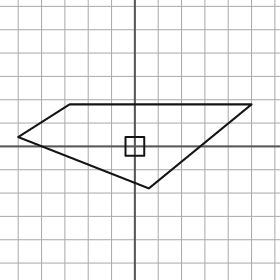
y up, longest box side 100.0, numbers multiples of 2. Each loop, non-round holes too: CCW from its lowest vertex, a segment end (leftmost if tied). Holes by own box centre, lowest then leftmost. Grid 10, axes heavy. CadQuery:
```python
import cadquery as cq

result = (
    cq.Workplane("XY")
    .moveTo(6.0, -18.0)
    .lineTo(50.0, 18.0)
    .lineTo(-28.0, 18.0)
    .lineTo(-50.0, 4.0)
    .close()
    .moveTo(-4.0, -4.0)
    .lineTo(4.0, -4.0)
    .lineTo(4.0, 4.0)
    .lineTo(-4.0, 4.0)
    .close()
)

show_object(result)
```